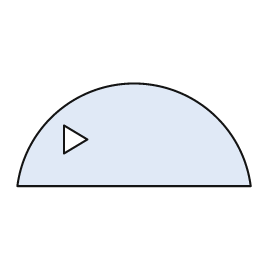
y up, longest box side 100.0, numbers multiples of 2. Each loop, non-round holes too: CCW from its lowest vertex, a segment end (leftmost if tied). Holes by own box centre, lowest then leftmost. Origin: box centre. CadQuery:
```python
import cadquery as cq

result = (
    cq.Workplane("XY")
    .moveTo(-50.0, -22.0)
    .lineTo(50.0, -22.0)
    .threePointArc((0.0, 22.0), (-50.0, -22.0))
    .close()
    .moveTo(-30.0, -8.0)
    .lineTo(-20.0, -2.0)
    .lineTo(-30.0, 4.0)
    .close()
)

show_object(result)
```